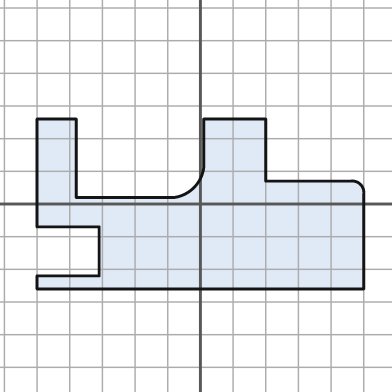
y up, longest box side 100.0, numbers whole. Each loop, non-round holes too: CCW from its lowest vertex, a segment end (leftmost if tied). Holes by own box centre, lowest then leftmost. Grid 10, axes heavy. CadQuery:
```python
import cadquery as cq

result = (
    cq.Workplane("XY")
    .moveTo(-50.0, -26.0)
    .lineTo(50.0, -26.0)
    .lineTo(50.0, 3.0)
    .threePointArc((49.0, 6.0), (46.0, 7.0))
    .lineTo(20.0, 7.0)
    .lineTo(20.0, 26.0)
    .lineTo(1.0, 26.0)
    .lineTo(1.0, 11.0)
    .threePointArc((-2.0, 5.0), (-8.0, 2.0))
    .lineTo(-38.0, 2.0)
    .lineTo(-38.0, 26.0)
    .lineTo(-50.0, 26.0)
    .lineTo(-50.0, -7.0)
    .lineTo(-31.0, -7.0)
    .lineTo(-31.0, -22.0)
    .lineTo(-50.0, -22.0)
    .close()
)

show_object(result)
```